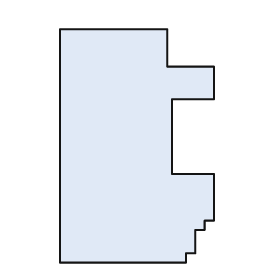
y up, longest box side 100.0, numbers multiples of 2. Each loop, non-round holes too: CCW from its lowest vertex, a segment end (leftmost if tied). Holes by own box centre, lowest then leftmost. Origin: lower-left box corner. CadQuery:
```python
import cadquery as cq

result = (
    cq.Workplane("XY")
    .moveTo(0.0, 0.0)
    .lineTo(54.0, 0.0)
    .lineTo(54.0, 4.0)
    .lineTo(58.0, 4.0)
    .lineTo(58.0, 14.0)
    .lineTo(62.0, 14.0)
    .lineTo(62.0, 18.0)
    .lineTo(66.0, 18.0)
    .lineTo(66.0, 38.0)
    .lineTo(48.0, 38.0)
    .lineTo(48.0, 70.0)
    .lineTo(66.0, 70.0)
    .lineTo(66.0, 84.0)
    .lineTo(46.0, 84.0)
    .lineTo(46.0, 100.0)
    .lineTo(0.0, 100.0)
    .close()
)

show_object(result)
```